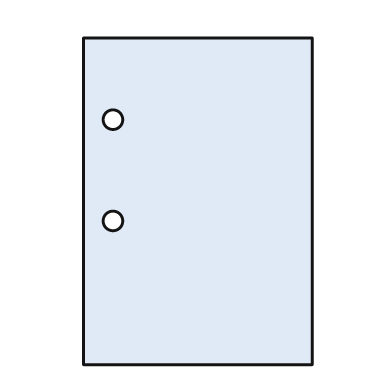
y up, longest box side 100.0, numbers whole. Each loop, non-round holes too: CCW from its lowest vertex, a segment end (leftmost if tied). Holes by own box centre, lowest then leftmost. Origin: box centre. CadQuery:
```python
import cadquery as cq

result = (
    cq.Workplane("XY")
    .moveTo(-35.0, -50.0)
    .lineTo(35.0, -50.0)
    .lineTo(35.0, 50.0)
    .lineTo(-35.0, 50.0)
    .close()
    .moveTo(-26.0, -6.0)
    .circle(3.0)
    .moveTo(-26.0, 25.0)
    .circle(3.0)
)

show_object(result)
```